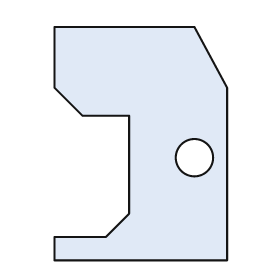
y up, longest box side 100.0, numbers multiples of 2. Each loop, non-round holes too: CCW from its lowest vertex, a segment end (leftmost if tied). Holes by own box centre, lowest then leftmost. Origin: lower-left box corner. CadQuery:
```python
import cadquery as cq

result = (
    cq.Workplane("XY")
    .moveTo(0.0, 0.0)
    .lineTo(74.0, 0.0)
    .lineTo(74.0, 74.0)
    .lineTo(60.0, 100.0)
    .lineTo(0.0, 100.0)
    .lineTo(0.0, 74.0)
    .lineTo(12.0, 62.0)
    .lineTo(32.0, 62.0)
    .lineTo(32.0, 20.0)
    .lineTo(22.0, 10.0)
    .lineTo(0.0, 10.0)
    .close()
    .moveTo(60.0, 44.0)
    .circle(8.0)
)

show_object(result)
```